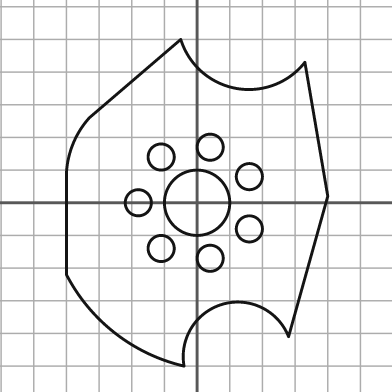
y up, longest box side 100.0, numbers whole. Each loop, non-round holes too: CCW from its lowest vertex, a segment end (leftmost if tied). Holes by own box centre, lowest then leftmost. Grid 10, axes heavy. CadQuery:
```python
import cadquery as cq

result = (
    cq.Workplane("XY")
    .moveTo(-4.0, -50.0)
    .threePointArc((8.0, -31.0), (28.0, -41.0))
    .lineTo(40.0, 2.0)
    .lineTo(33.0, 43.0)
    .threePointArc((12.0, 35.0), (-5.0, 50.0))
    .lineTo(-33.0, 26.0)
    .threePointArc((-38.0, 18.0), (-40.0, 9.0))
    .lineTo(-40.0, -22.0)
    .threePointArc((-25.0, -40.0), (-4.0, -50.0))
    .close()
    .moveTo(4.0, -17.0)
    .circle(4.0)
    .moveTo(-11.0, -14.0)
    .circle(4.0)
    .moveTo(16.0, -8.0)
    .circle(4.0)
    .moveTo(-18.0, 0.0)
    .circle(4.0)
    .moveTo(0.0, 0.0)
    .circle(10.0)
    .moveTo(16.0, 8.0)
    .circle(4.0)
    .moveTo(-11.0, 14.0)
    .circle(4.0)
    .moveTo(4.0, 17.0)
    .circle(4.0)
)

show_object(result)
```